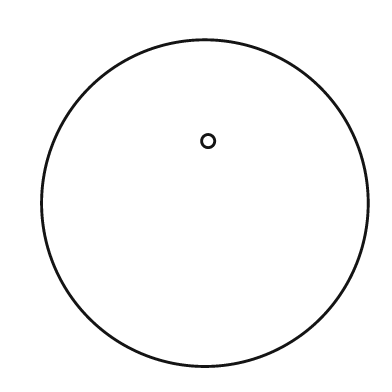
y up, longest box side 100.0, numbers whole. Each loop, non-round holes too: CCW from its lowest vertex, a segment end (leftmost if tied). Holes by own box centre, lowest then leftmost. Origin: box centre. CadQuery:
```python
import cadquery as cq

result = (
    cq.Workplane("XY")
    .moveTo(0.0, 0.0)
    .circle(50.0)
    .moveTo(1.0, 19.0)
    .circle(2.0)
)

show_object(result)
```